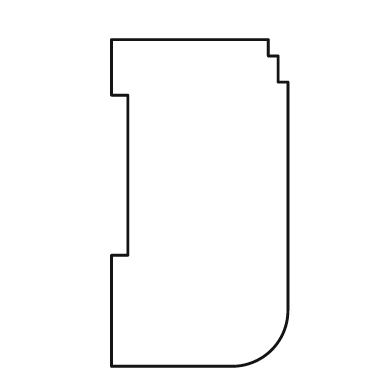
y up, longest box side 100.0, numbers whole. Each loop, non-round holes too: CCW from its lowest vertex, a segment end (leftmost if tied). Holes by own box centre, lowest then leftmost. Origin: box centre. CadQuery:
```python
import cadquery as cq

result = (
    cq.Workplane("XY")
    .moveTo(-27.0, -50.0)
    .lineTo(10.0, -50.0)
    .threePointArc((22.0, -45.0), (27.0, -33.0))
    .lineTo(27.0, 37.0)
    .lineTo(24.0, 37.0)
    .lineTo(24.0, 45.0)
    .lineTo(21.0, 45.0)
    .lineTo(21.0, 50.0)
    .lineTo(-27.0, 50.0)
    .lineTo(-27.0, 33.0)
    .lineTo(-22.0, 33.0)
    .lineTo(-22.0, -16.0)
    .lineTo(-27.0, -16.0)
    .close()
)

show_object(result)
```